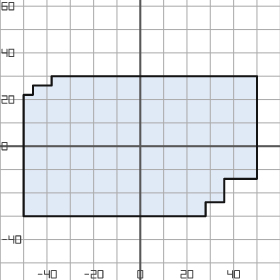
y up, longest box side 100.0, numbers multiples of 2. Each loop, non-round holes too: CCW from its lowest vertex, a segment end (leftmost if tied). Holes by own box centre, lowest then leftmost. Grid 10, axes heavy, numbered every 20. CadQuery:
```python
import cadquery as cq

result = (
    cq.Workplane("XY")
    .moveTo(-50.0, -30.0)
    .lineTo(28.0, -30.0)
    .lineTo(28.0, -24.0)
    .lineTo(36.0, -24.0)
    .lineTo(36.0, -14.0)
    .lineTo(50.0, -14.0)
    .lineTo(50.0, 30.0)
    .lineTo(-38.0, 30.0)
    .lineTo(-38.0, 26.0)
    .lineTo(-46.0, 26.0)
    .lineTo(-46.0, 22.0)
    .lineTo(-50.0, 22.0)
    .close()
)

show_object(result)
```